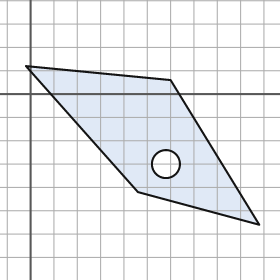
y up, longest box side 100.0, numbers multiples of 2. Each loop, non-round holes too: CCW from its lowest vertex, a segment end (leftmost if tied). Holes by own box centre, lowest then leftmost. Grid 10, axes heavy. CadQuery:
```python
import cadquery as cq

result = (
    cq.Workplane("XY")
    .moveTo(98.0, -56.0)
    .lineTo(60.0, 6.0)
    .lineTo(-2.0, 12.0)
    .lineTo(46.0, -42.0)
    .close()
    .moveTo(58.0, -30.0)
    .circle(6.0)
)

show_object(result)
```